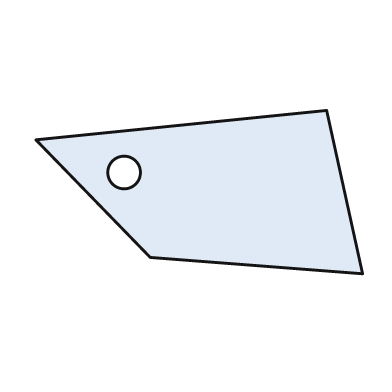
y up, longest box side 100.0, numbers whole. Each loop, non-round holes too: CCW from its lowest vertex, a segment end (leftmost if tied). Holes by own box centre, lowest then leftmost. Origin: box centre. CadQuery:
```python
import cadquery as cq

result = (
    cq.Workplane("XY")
    .moveTo(50.0, -25.0)
    .lineTo(39.0, 25.0)
    .lineTo(-50.0, 16.0)
    .lineTo(-15.0, -20.0)
    .close()
    .moveTo(-23.0, 6.0)
    .circle(5.0)
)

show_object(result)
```